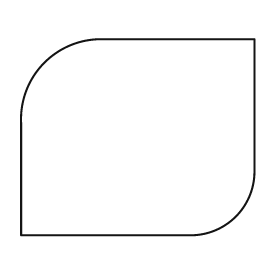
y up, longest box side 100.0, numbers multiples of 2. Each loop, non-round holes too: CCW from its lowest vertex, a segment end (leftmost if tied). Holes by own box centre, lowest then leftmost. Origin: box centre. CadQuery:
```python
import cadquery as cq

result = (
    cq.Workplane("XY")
    .moveTo(-50.0, -42.0)
    .lineTo(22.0, -42.0)
    .threePointArc((42.0, -34.0), (50.0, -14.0))
    .lineTo(50.0, 42.0)
    .lineTo(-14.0, 42.0)
    .threePointArc((-40.0, 32.0), (-50.0, 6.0))
    .close()
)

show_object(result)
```